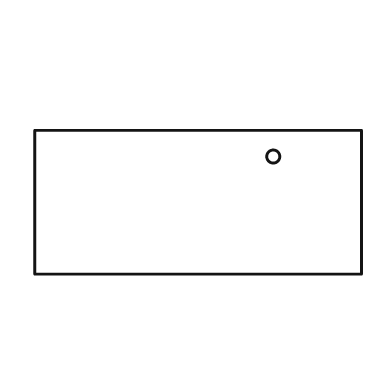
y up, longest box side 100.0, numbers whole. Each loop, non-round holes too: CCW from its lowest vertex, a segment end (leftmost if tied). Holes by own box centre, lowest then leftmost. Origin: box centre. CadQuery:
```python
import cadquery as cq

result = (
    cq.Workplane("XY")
    .moveTo(-50.0, -22.0)
    .lineTo(50.0, -22.0)
    .lineTo(50.0, 22.0)
    .lineTo(-50.0, 22.0)
    .close()
    .moveTo(23.0, 14.0)
    .circle(2.0)
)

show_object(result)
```